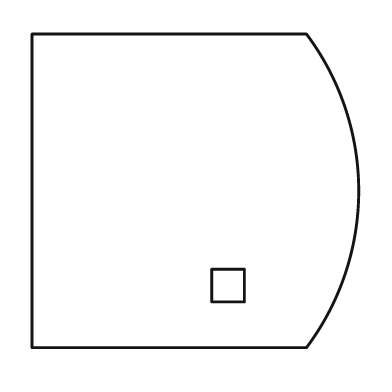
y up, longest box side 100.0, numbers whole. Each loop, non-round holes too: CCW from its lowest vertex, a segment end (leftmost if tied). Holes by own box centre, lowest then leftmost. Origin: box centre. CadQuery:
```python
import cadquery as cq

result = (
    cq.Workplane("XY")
    .moveTo(-50.0, -48.0)
    .lineTo(34.0, -48.0)
    .threePointArc((50.0, 0.0), (34.0, 48.0))
    .lineTo(-50.0, 48.0)
    .close()
    .moveTo(5.0, -34.0)
    .lineTo(15.0, -34.0)
    .lineTo(15.0, -24.0)
    .lineTo(5.0, -24.0)
    .close()
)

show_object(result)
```